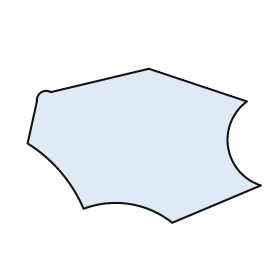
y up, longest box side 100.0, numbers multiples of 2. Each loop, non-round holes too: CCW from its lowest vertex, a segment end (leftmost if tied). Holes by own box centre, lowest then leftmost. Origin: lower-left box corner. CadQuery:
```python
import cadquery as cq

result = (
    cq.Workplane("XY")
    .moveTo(62.0, 0.0)
    .lineTo(100.0, 16.0)
    .threePointArc((86.0, 32.0), (94.0, 52.0))
    .lineTo(52.0, 66.0)
    .lineTo(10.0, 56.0)
    .threePointArc((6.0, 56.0), (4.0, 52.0))
    .lineTo(0.0, 34.0)
    .threePointArc((14.0, 22.0), (24.0, 6.0))
    .threePointArc((44.0, 8.0), (62.0, 0.0))
    .close()
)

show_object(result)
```